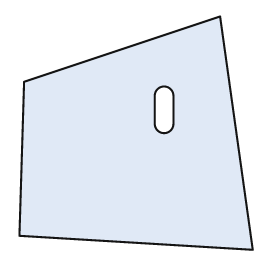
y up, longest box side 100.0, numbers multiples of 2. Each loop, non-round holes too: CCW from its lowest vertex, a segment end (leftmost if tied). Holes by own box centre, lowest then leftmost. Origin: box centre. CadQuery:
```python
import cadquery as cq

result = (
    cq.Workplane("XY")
    .moveTo(50.0, -50.0)
    .lineTo(36.0, 50.0)
    .lineTo(-48.0, 22.0)
    .lineTo(-50.0, -44.0)
    .close()
    .moveTo(8.0, 4.0)
    .threePointArc((12.0, 0.0), (16.0, 4.0))
    .lineTo(16.0, 16.0)
    .threePointArc((12.0, 20.0), (8.0, 16.0))
    .close()
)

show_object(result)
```